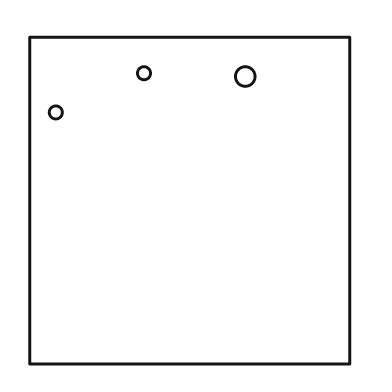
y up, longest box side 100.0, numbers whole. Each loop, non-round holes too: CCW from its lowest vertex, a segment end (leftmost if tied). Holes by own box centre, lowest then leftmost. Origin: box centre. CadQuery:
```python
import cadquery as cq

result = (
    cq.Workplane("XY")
    .moveTo(-49.0, -50.0)
    .lineTo(49.0, -50.0)
    .lineTo(49.0, 50.0)
    .lineTo(-49.0, 50.0)
    .close()
    .moveTo(-41.0, 27.0)
    .circle(2.0)
    .moveTo(17.0, 38.0)
    .circle(3.0)
    .moveTo(-14.0, 39.0)
    .circle(2.0)
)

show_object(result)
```